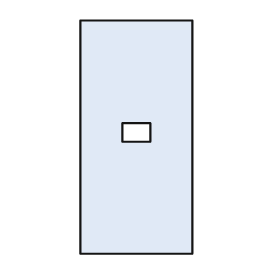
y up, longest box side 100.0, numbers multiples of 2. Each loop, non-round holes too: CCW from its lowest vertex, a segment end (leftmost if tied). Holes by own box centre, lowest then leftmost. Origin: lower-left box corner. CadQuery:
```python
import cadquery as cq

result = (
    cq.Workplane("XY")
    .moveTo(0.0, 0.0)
    .lineTo(48.0, 0.0)
    .lineTo(48.0, 100.0)
    .lineTo(0.0, 100.0)
    .close()
    .moveTo(18.0, 48.0)
    .lineTo(30.0, 48.0)
    .lineTo(30.0, 56.0)
    .lineTo(18.0, 56.0)
    .close()
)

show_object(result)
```